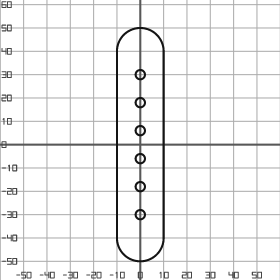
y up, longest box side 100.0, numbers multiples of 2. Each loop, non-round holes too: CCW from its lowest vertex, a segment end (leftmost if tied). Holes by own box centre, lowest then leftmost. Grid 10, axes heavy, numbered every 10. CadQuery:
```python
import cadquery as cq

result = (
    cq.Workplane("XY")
    .moveTo(-10.0, -40.0)
    .threePointArc((0.0, -50.0), (10.0, -40.0))
    .lineTo(10.0, 40.0)
    .threePointArc((0.0, 50.0), (-10.0, 40.0))
    .close()
    .moveTo(0.0, -30.0)
    .circle(2.0)
    .moveTo(0.0, -18.0)
    .circle(2.0)
    .moveTo(0.0, -6.0)
    .circle(2.0)
    .moveTo(0.0, 6.0)
    .circle(2.0)
    .moveTo(0.0, 18.0)
    .circle(2.0)
    .moveTo(0.0, 30.0)
    .circle(2.0)
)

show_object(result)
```